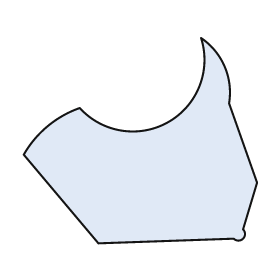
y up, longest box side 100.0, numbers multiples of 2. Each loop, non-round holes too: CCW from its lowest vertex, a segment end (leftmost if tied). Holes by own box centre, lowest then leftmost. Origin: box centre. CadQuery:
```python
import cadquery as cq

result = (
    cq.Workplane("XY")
    .moveTo(-18.0, -44.0)
    .lineTo(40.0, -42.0)
    .threePointArc((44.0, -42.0), (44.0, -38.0))
    .lineTo(50.0, -18.0)
    .lineTo(38.0, 16.0)
    .threePointArc((36.0, 32.0), (26.0, 44.0))
    .threePointArc((12.0, 8.0), (-26.0, 14.0))
    .threePointArc((-40.0, 6.0), (-50.0, -6.0))
    .close()
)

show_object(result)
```